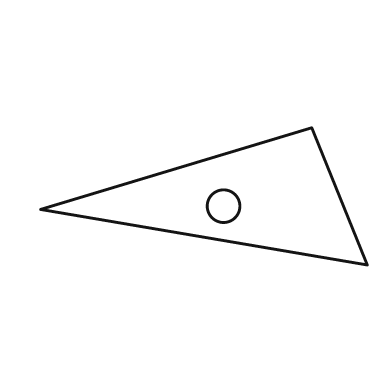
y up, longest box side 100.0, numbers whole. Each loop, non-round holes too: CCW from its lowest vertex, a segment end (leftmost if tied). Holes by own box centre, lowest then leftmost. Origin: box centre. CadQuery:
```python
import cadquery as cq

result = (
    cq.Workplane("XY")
    .moveTo(50.0, -21.0)
    .lineTo(33.0, 21.0)
    .lineTo(-50.0, -4.0)
    .close()
    .moveTo(6.0, -3.0)
    .circle(5.0)
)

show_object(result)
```